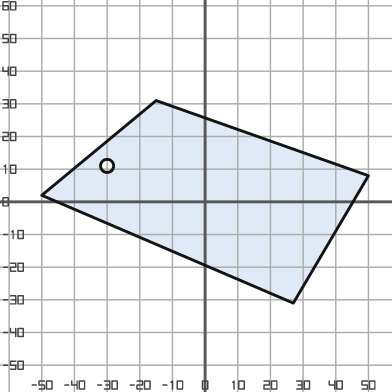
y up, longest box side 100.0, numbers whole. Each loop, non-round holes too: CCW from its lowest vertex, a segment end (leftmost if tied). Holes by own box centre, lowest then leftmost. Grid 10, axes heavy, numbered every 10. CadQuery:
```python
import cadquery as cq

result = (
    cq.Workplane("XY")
    .moveTo(27.0, -31.0)
    .lineTo(50.0, 8.0)
    .lineTo(-15.0, 31.0)
    .lineTo(-50.0, 2.0)
    .close()
    .moveTo(-30.0, 11.0)
    .circle(2.0)
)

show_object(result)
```